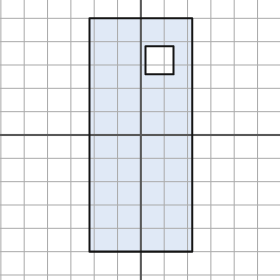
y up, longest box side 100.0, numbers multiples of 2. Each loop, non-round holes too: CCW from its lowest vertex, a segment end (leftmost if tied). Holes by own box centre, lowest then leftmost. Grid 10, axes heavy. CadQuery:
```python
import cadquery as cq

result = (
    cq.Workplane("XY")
    .moveTo(-22.0, -50.0)
    .lineTo(22.0, -50.0)
    .lineTo(22.0, 50.0)
    .lineTo(-22.0, 50.0)
    .close()
    .moveTo(2.0, 26.0)
    .lineTo(14.0, 26.0)
    .lineTo(14.0, 38.0)
    .lineTo(2.0, 38.0)
    .close()
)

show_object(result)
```